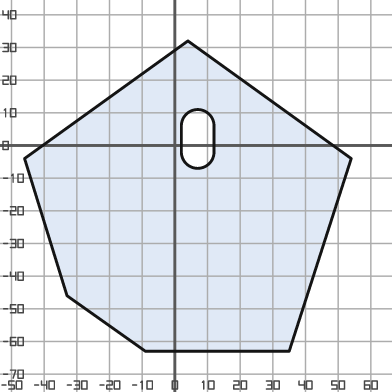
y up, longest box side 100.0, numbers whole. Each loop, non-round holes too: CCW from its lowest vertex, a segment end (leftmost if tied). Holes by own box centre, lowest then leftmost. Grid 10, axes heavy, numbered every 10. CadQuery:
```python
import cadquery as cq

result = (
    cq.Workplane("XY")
    .moveTo(-9.0, -63.0)
    .lineTo(35.0, -63.0)
    .lineTo(54.0, -4.0)
    .lineTo(4.0, 32.0)
    .lineTo(-46.0, -4.0)
    .lineTo(-33.0, -46.0)
    .close()
    .moveTo(2.0, -2.0)
    .threePointArc((7.0, -7.0), (12.0, -2.0))
    .lineTo(12.0, 6.0)
    .threePointArc((7.0, 11.0), (2.0, 6.0))
    .close()
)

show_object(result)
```